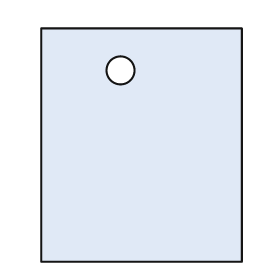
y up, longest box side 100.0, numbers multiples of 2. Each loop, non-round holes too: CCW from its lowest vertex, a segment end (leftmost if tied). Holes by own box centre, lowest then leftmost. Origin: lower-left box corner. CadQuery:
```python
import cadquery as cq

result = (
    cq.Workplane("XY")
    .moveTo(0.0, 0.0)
    .lineTo(86.0, 0.0)
    .lineTo(86.0, 100.0)
    .lineTo(0.0, 100.0)
    .close()
    .moveTo(34.0, 82.0)
    .circle(6.0)
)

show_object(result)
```